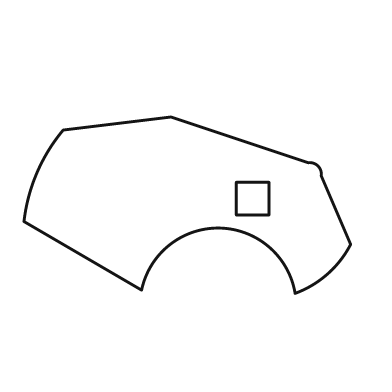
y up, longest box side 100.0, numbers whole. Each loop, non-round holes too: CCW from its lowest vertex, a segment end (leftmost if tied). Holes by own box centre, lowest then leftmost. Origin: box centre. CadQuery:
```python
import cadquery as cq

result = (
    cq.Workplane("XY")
    .moveTo(33.0, -27.0)
    .threePointArc((43.0, -21.0), (50.0, -12.0))
    .lineTo(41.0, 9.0)
    .threePointArc((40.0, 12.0), (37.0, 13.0))
    .lineTo(-5.0, 27.0)
    .lineTo(-38.0, 23.0)
    .threePointArc((-46.0, 10.0), (-50.0, -5.0))
    .lineTo(-14.0, -26.0)
    .threePointArc((10.0, -7.0), (33.0, -27.0))
    .close()
    .moveTo(15.0, -3.0)
    .lineTo(25.0, -3.0)
    .lineTo(25.0, 7.0)
    .lineTo(15.0, 7.0)
    .close()
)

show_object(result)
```